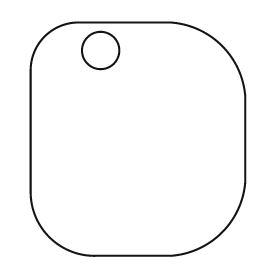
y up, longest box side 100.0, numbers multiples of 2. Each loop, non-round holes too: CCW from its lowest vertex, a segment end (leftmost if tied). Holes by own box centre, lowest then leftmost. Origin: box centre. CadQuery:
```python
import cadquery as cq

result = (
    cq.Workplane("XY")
    .moveTo(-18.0, -50.0)
    .lineTo(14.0, -50.0)
    .threePointArc((36.0, -40.0), (46.0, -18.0))
    .lineTo(46.0, 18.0)
    .threePointArc((36.0, 40.0), (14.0, 50.0))
    .lineTo(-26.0, 50.0)
    .threePointArc((-40.0, 44.0), (-46.0, 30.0))
    .lineTo(-46.0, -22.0)
    .threePointArc((-38.0, -42.0), (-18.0, -50.0))
    .close()
    .moveTo(-16.0, 38.0)
    .circle(8.0)
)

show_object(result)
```